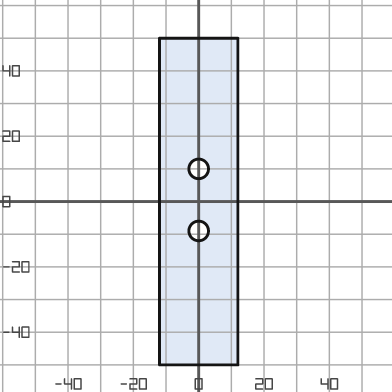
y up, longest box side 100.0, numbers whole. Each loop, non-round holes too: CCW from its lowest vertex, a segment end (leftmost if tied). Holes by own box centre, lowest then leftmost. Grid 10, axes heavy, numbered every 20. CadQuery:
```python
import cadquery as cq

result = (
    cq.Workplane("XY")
    .moveTo(-12.0, -50.0)
    .lineTo(12.0, -50.0)
    .lineTo(12.0, 50.0)
    .lineTo(-12.0, 50.0)
    .close()
    .moveTo(0.0, -9.0)
    .circle(3.0)
    .moveTo(0.0, 10.0)
    .circle(3.0)
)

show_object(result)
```